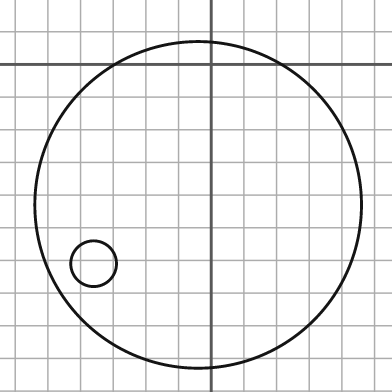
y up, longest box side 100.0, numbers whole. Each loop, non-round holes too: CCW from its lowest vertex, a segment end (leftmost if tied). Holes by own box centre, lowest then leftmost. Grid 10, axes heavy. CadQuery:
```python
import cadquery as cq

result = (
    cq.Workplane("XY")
    .moveTo(-4.0, -43.0)
    .circle(50.0)
    .moveTo(-36.0, -61.0)
    .circle(7.0)
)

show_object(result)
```